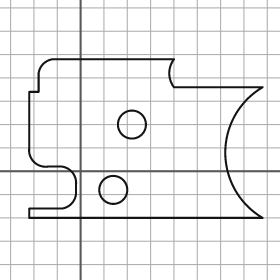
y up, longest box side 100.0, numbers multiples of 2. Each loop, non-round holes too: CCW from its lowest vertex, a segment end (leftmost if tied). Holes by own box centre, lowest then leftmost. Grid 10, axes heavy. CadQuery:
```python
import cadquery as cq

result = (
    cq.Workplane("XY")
    .moveTo(-22.0, -20.0)
    .lineTo(78.0, -20.0)
    .threePointArc((62.0, 8.0), (78.0, 36.0))
    .lineTo(40.0, 36.0)
    .threePointArc((38.0, 42.0), (40.0, 48.0))
    .lineTo(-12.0, 48.0)
    .threePointArc((-16.0, 46.0), (-18.0, 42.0))
    .lineTo(-18.0, 34.0)
    .lineTo(-22.0, 34.0)
    .lineTo(-22.0, 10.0)
    .threePointArc((-20.0, 4.0), (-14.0, 2.0))
    .lineTo(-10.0, 2.0)
    .threePointArc((-4.0, 0.0), (-2.0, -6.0))
    .lineTo(-2.0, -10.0)
    .threePointArc((-4.0, -14.0), (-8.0, -16.0))
    .lineTo(-22.0, -16.0)
    .close()
    .moveTo(14.0, -8.0)
    .circle(6.0)
    .moveTo(22.0, 20.0)
    .circle(6.0)
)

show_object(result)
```